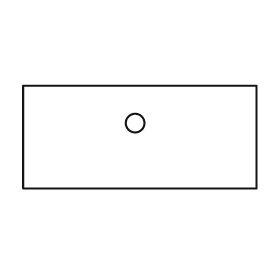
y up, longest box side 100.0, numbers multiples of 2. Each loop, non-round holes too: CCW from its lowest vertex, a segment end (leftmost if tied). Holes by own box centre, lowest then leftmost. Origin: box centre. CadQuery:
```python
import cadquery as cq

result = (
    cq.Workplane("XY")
    .moveTo(-50.0, -22.0)
    .lineTo(50.0, -22.0)
    .lineTo(50.0, 22.0)
    .lineTo(-50.0, 22.0)
    .close()
    .moveTo(-2.0, 6.0)
    .circle(4.0)
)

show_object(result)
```